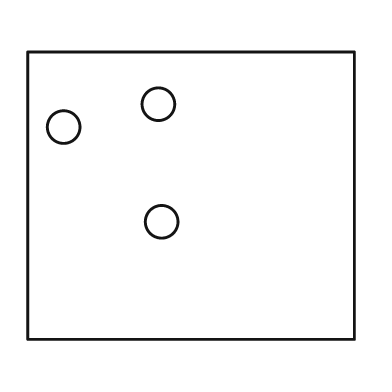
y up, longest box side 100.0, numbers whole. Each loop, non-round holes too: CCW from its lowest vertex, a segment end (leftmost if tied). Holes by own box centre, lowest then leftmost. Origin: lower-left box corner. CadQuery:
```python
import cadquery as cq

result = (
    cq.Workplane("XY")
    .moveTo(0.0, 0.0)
    .lineTo(100.0, 0.0)
    .lineTo(100.0, 88.0)
    .lineTo(0.0, 88.0)
    .close()
    .moveTo(41.0, 36.0)
    .circle(5.0)
    .moveTo(11.0, 65.0)
    .circle(5.0)
    .moveTo(40.0, 72.0)
    .circle(5.0)
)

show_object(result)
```